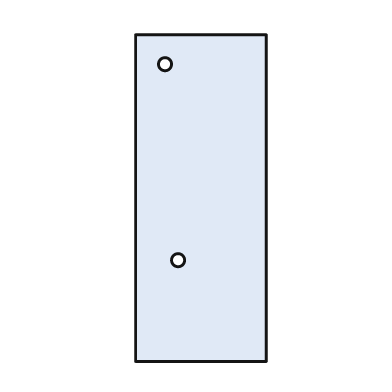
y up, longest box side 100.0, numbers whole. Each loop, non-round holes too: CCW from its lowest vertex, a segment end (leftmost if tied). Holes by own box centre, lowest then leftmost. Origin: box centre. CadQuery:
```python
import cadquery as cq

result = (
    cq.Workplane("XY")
    .moveTo(-20.0, -50.0)
    .lineTo(20.0, -50.0)
    .lineTo(20.0, 50.0)
    .lineTo(-20.0, 50.0)
    .close()
    .moveTo(-7.0, -19.0)
    .circle(2.0)
    .moveTo(-11.0, 41.0)
    .circle(2.0)
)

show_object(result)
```